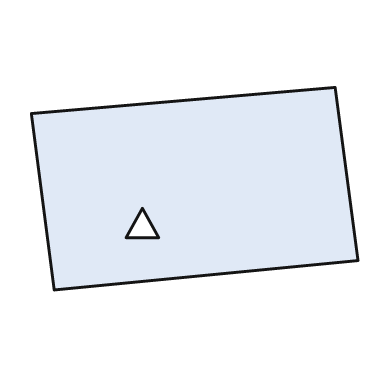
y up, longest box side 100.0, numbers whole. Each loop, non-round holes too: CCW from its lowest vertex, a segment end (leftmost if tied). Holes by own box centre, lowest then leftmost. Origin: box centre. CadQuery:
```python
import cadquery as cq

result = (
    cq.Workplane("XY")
    .moveTo(-43.0, -31.0)
    .lineTo(50.0, -22.0)
    .lineTo(43.0, 31.0)
    .lineTo(-50.0, 23.0)
    .close()
    .moveTo(-21.0, -15.0)
    .lineTo(-11.0, -15.0)
    .lineTo(-16.0, -6.0)
    .close()
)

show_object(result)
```